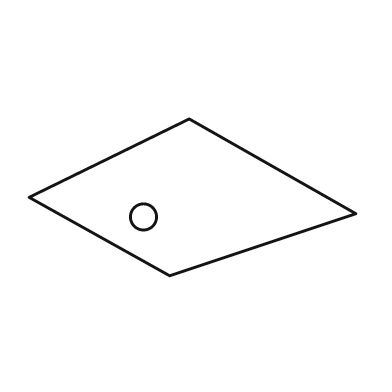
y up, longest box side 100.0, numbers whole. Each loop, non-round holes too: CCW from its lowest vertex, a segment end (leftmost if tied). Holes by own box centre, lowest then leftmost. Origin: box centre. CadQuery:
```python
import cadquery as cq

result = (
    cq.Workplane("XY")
    .moveTo(-7.0, -24.0)
    .lineTo(50.0, -5.0)
    .lineTo(-1.0, 24.0)
    .lineTo(-50.0, 0.0)
    .close()
    .moveTo(-15.0, -6.0)
    .circle(4.0)
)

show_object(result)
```